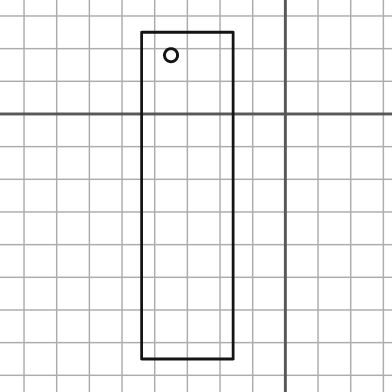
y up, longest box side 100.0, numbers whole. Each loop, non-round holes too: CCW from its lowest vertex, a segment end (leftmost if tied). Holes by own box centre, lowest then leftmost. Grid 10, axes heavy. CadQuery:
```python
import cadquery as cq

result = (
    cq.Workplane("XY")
    .moveTo(-44.0, -75.0)
    .lineTo(-16.0, -75.0)
    .lineTo(-16.0, 25.0)
    .lineTo(-44.0, 25.0)
    .close()
    .moveTo(-35.0, 18.0)
    .circle(2.0)
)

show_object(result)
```